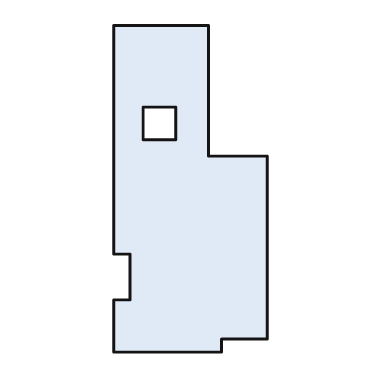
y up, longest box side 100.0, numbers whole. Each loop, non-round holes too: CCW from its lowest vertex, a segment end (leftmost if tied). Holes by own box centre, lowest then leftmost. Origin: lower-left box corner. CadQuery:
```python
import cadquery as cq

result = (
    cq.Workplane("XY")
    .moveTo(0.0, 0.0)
    .lineTo(33.0, 0.0)
    .lineTo(33.0, 4.0)
    .lineTo(47.0, 4.0)
    .lineTo(47.0, 60.0)
    .lineTo(29.0, 60.0)
    .lineTo(29.0, 100.0)
    .lineTo(0.0, 100.0)
    .lineTo(0.0, 30.0)
    .lineTo(5.0, 30.0)
    .lineTo(5.0, 16.0)
    .lineTo(0.0, 16.0)
    .close()
    .moveTo(9.0, 65.0)
    .lineTo(19.0, 65.0)
    .lineTo(19.0, 75.0)
    .lineTo(9.0, 75.0)
    .close()
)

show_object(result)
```